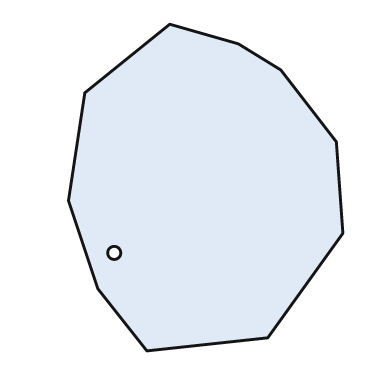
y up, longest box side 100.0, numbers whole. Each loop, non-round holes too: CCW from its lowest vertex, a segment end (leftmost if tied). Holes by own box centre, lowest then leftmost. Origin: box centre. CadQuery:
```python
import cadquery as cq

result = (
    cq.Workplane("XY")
    .moveTo(-18.0, -50.0)
    .lineTo(19.0, -46.0)
    .lineTo(42.0, -14.0)
    .lineTo(40.0, 14.0)
    .lineTo(23.0, 36.0)
    .lineTo(10.0, 44.0)
    .lineTo(-11.0, 50.0)
    .lineTo(-37.0, 29.0)
    .lineTo(-42.0, -4.0)
    .lineTo(-33.0, -31.0)
    .close()
    .moveTo(-28.0, -20.0)
    .circle(2.0)
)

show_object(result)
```